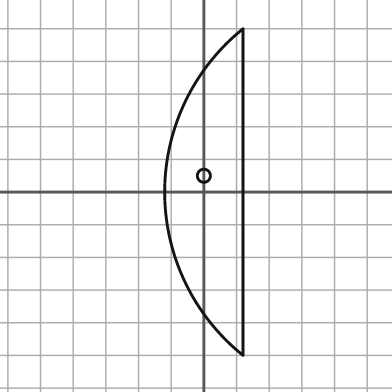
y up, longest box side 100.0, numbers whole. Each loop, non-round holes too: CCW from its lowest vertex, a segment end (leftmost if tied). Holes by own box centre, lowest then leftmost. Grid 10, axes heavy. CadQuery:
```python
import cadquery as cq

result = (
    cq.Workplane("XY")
    .moveTo(12.0, -50.0)
    .lineTo(12.0, 50.0)
    .threePointArc((-12.0, 0.0), (12.0, -50.0))
    .close()
    .moveTo(0.0, 5.0)
    .circle(2.0)
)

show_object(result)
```